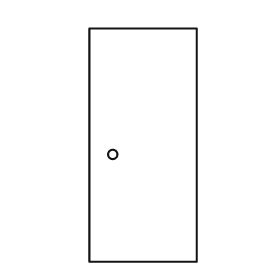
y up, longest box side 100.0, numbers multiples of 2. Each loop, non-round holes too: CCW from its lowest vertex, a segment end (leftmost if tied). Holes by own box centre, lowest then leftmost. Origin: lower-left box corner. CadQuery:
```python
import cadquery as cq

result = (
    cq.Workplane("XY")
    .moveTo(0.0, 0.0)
    .lineTo(46.0, 0.0)
    .lineTo(46.0, 100.0)
    .lineTo(0.0, 100.0)
    .close()
    .moveTo(10.0, 46.0)
    .circle(2.0)
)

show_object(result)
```